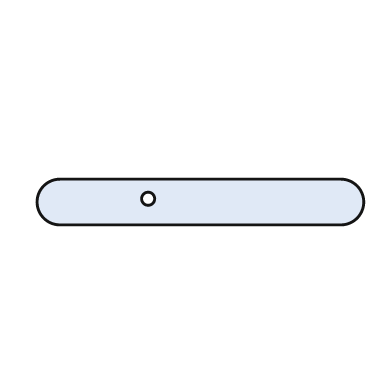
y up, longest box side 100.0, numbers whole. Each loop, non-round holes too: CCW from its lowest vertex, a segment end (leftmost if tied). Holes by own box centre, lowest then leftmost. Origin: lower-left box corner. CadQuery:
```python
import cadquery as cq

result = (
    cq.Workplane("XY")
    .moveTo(7.0, 0.0)
    .lineTo(93.0, 0.0)
    .threePointArc((100.0, 7.0), (93.0, 14.0))
    .lineTo(7.0, 14.0)
    .threePointArc((0.0, 7.0), (7.0, 0.0))
    .close()
    .moveTo(34.0, 8.0)
    .circle(2.0)
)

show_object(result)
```